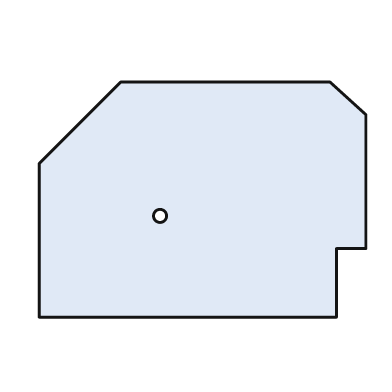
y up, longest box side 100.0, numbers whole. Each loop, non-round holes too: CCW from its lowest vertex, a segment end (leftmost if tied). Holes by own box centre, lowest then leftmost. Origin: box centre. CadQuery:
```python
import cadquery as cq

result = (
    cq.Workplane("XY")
    .moveTo(-50.0, -36.0)
    .lineTo(41.0, -36.0)
    .lineTo(41.0, -15.0)
    .lineTo(50.0, -15.0)
    .lineTo(50.0, 26.0)
    .lineTo(39.0, 36.0)
    .lineTo(-25.0, 36.0)
    .lineTo(-50.0, 11.0)
    .close()
    .moveTo(-13.0, -5.0)
    .circle(2.0)
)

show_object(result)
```